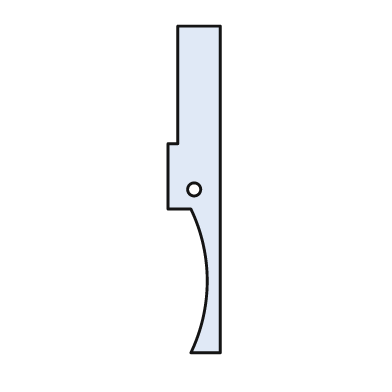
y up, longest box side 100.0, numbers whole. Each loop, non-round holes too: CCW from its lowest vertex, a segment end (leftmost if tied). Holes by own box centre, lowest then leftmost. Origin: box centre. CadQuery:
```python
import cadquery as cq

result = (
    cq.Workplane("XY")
    .moveTo(-1.0, -50.0)
    .lineTo(8.0, -50.0)
    .lineTo(8.0, 50.0)
    .lineTo(-5.0, 50.0)
    .lineTo(-5.0, 14.0)
    .lineTo(-8.0, 14.0)
    .lineTo(-8.0, -6.0)
    .lineTo(-1.0, -6.0)
    .threePointArc((4.0, -28.0), (-1.0, -50.0))
    .close()
    .moveTo(0.0, 0.0)
    .circle(2.0)
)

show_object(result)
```